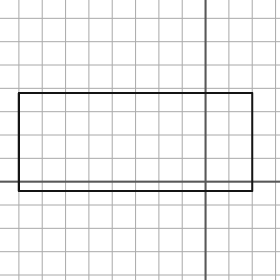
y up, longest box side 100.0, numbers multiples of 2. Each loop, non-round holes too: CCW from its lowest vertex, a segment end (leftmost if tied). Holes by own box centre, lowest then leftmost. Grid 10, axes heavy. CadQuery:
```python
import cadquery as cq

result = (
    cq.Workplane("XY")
    .moveTo(-80.0, -4.0)
    .lineTo(20.0, -4.0)
    .lineTo(20.0, 38.0)
    .lineTo(-80.0, 38.0)
    .close()
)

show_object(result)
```